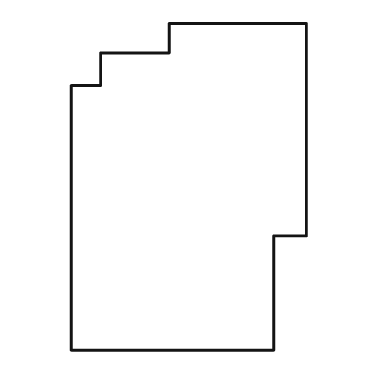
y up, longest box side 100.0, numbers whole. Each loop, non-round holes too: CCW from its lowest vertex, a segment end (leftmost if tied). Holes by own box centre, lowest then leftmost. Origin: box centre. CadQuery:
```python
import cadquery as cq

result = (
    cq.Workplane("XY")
    .moveTo(-36.0, -50.0)
    .lineTo(26.0, -50.0)
    .lineTo(26.0, -15.0)
    .lineTo(36.0, -15.0)
    .lineTo(36.0, 50.0)
    .lineTo(-6.0, 50.0)
    .lineTo(-6.0, 41.0)
    .lineTo(-27.0, 41.0)
    .lineTo(-27.0, 31.0)
    .lineTo(-36.0, 31.0)
    .close()
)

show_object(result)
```